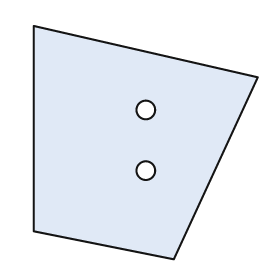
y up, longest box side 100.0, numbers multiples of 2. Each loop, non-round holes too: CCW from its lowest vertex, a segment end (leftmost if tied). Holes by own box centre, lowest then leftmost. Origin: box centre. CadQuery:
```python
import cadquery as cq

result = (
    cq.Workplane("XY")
    .moveTo(12.0, -50.0)
    .lineTo(48.0, 28.0)
    .lineTo(-48.0, 50.0)
    .lineTo(-48.0, -38.0)
    .close()
    .moveTo(0.0, -12.0)
    .circle(4.0)
    .moveTo(0.0, 14.0)
    .circle(4.0)
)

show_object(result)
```